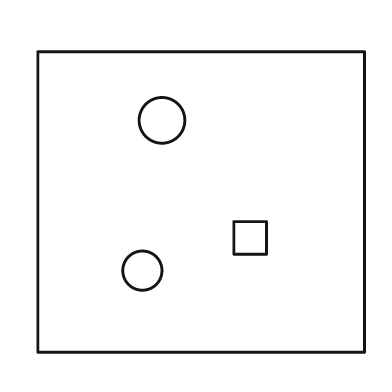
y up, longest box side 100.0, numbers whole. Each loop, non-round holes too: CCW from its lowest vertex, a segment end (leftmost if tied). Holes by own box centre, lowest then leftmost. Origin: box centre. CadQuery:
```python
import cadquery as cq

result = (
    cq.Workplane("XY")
    .moveTo(-50.0, -46.0)
    .lineTo(50.0, -46.0)
    .lineTo(50.0, 46.0)
    .lineTo(-50.0, 46.0)
    .close()
    .moveTo(-18.0, -21.0)
    .circle(6.0)
    .moveTo(10.0, -16.0)
    .lineTo(20.0, -16.0)
    .lineTo(20.0, -6.0)
    .lineTo(10.0, -6.0)
    .close()
    .moveTo(-12.0, 25.0)
    .circle(7.0)
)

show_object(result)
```